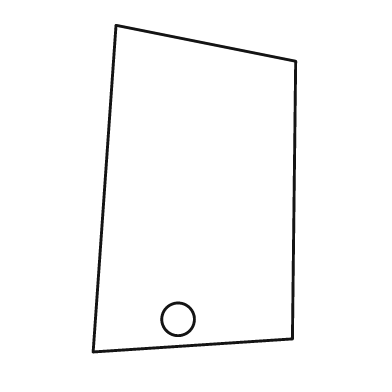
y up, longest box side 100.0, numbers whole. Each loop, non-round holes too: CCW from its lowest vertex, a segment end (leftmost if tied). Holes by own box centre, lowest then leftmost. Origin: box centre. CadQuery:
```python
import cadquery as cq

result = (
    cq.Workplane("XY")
    .moveTo(-31.0, -50.0)
    .lineTo(30.0, -46.0)
    .lineTo(31.0, 39.0)
    .lineTo(-24.0, 50.0)
    .close()
    .moveTo(-5.0, -40.0)
    .circle(5.0)
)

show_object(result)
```